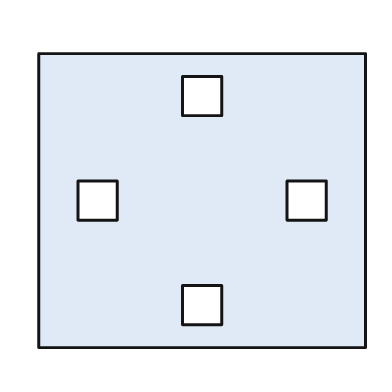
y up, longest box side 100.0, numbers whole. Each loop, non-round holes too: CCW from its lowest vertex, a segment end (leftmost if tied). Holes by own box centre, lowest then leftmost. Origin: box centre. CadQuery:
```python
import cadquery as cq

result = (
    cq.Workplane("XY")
    .moveTo(-50.0, -45.0)
    .lineTo(50.0, -45.0)
    .lineTo(50.0, 45.0)
    .lineTo(-50.0, 45.0)
    .close()
    .moveTo(-6.0, -38.0)
    .lineTo(6.0, -38.0)
    .lineTo(6.0, -26.0)
    .lineTo(-6.0, -26.0)
    .close()
    .moveTo(-38.0, -6.0)
    .lineTo(-26.0, -6.0)
    .lineTo(-26.0, 6.0)
    .lineTo(-38.0, 6.0)
    .close()
    .moveTo(26.0, -6.0)
    .lineTo(38.0, -6.0)
    .lineTo(38.0, 6.0)
    .lineTo(26.0, 6.0)
    .close()
    .moveTo(-6.0, 26.0)
    .lineTo(6.0, 26.0)
    .lineTo(6.0, 38.0)
    .lineTo(-6.0, 38.0)
    .close()
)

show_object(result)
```